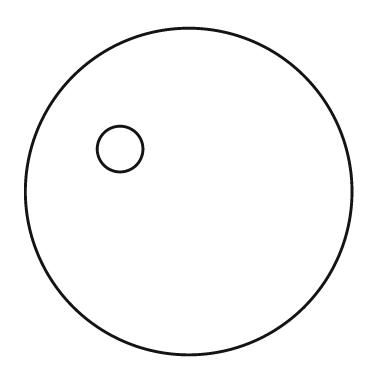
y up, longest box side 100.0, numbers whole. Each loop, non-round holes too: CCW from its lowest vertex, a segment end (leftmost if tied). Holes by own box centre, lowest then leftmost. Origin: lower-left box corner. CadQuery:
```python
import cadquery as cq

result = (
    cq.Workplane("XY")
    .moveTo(50.0, 50.0)
    .circle(50.0)
    .moveTo(29.0, 63.0)
    .circle(7.0)
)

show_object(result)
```